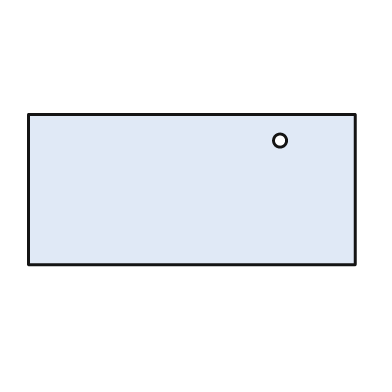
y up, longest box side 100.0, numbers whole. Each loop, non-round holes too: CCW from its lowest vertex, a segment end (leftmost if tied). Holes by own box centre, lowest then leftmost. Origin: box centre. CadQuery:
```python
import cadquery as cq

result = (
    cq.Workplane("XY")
    .moveTo(-50.0, -23.0)
    .lineTo(50.0, -23.0)
    .lineTo(50.0, 23.0)
    .lineTo(-50.0, 23.0)
    .close()
    .moveTo(27.0, 15.0)
    .circle(2.0)
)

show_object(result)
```